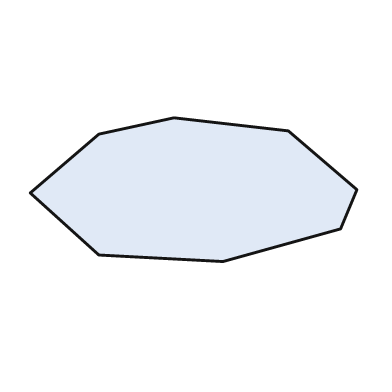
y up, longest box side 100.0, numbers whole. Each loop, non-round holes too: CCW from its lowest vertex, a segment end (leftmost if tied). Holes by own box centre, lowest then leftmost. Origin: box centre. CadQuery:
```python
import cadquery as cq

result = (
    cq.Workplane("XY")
    .moveTo(9.0, -22.0)
    .lineTo(45.0, -12.0)
    .lineTo(50.0, 0.0)
    .lineTo(29.0, 18.0)
    .lineTo(-6.0, 22.0)
    .lineTo(-29.0, 17.0)
    .lineTo(-50.0, -1.0)
    .lineTo(-29.0, -20.0)
    .close()
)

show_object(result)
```